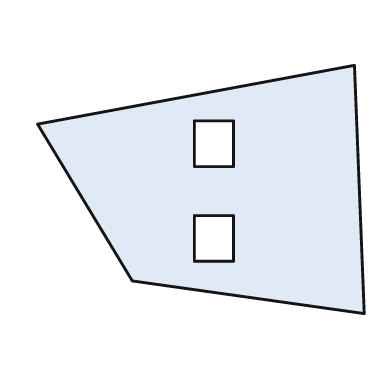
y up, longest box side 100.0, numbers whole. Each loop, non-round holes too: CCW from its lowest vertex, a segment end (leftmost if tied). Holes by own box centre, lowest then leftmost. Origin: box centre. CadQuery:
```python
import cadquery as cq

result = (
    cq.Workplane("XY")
    .moveTo(50.0, -38.0)
    .lineTo(47.0, 38.0)
    .lineTo(-50.0, 20.0)
    .lineTo(-21.0, -28.0)
    .close()
    .moveTo(-2.0, -22.0)
    .lineTo(10.0, -22.0)
    .lineTo(10.0, -8.0)
    .lineTo(-2.0, -8.0)
    .close()
    .moveTo(-2.0, 7.0)
    .lineTo(10.0, 7.0)
    .lineTo(10.0, 21.0)
    .lineTo(-2.0, 21.0)
    .close()
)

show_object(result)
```